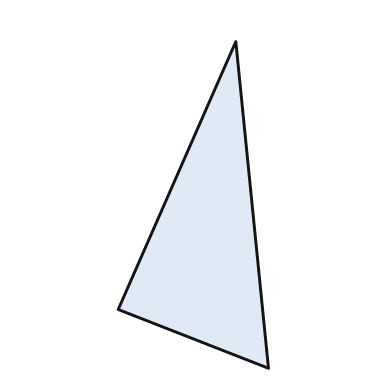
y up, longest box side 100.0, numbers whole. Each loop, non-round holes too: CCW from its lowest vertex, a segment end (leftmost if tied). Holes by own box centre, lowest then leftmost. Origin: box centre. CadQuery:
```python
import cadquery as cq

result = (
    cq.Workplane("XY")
    .moveTo(23.0, -50.0)
    .lineTo(13.0, 50.0)
    .lineTo(-23.0, -32.0)
    .close()
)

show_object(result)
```